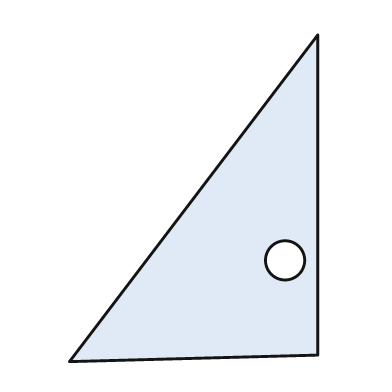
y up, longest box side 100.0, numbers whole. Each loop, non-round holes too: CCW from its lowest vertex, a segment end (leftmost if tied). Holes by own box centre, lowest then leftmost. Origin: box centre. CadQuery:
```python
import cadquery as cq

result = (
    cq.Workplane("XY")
    .moveTo(-38.0, -50.0)
    .lineTo(38.0, -48.0)
    .lineTo(38.0, 50.0)
    .close()
    .moveTo(28.0, -19.0)
    .circle(6.0)
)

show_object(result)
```